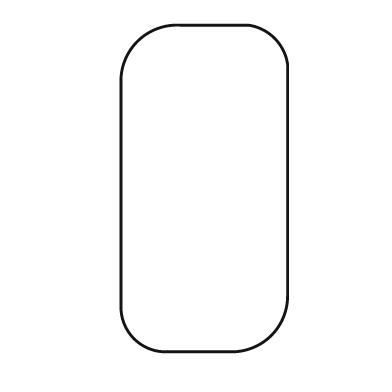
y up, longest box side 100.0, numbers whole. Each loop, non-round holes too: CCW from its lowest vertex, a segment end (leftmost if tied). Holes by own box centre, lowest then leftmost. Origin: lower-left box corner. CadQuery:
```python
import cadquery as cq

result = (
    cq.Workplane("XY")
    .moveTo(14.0, 0.0)
    .lineTo(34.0, 0.0)
    .threePointArc((46.0, 5.0), (51.0, 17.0))
    .lineTo(51.0, 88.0)
    .threePointArc((47.0, 96.0), (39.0, 100.0))
    .lineTo(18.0, 100.0)
    .threePointArc((5.0, 95.0), (0.0, 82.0))
    .lineTo(0.0, 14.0)
    .threePointArc((4.0, 4.0), (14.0, 0.0))
    .close()
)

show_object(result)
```